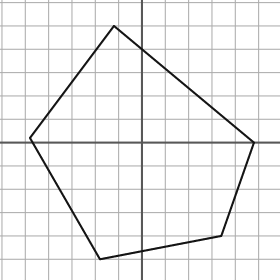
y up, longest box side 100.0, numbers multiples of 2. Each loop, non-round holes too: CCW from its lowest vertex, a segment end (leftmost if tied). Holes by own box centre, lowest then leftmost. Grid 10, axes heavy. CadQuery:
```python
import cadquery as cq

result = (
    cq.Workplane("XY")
    .moveTo(-18.0, -50.0)
    .lineTo(34.0, -40.0)
    .lineTo(48.0, 0.0)
    .lineTo(-12.0, 50.0)
    .lineTo(-48.0, 2.0)
    .close()
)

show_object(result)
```